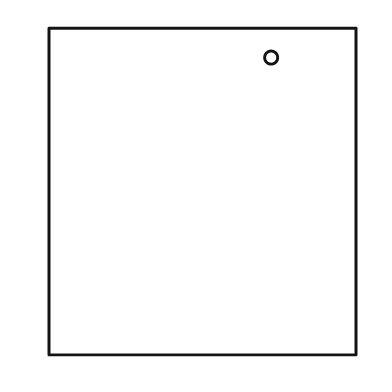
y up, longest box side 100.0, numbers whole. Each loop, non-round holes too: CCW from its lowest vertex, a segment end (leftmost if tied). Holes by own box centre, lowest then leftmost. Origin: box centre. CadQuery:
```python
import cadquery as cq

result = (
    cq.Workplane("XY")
    .moveTo(-47.0, -50.0)
    .lineTo(47.0, -50.0)
    .lineTo(47.0, 50.0)
    .lineTo(-47.0, 50.0)
    .close()
    .moveTo(21.0, 41.0)
    .circle(2.0)
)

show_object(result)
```